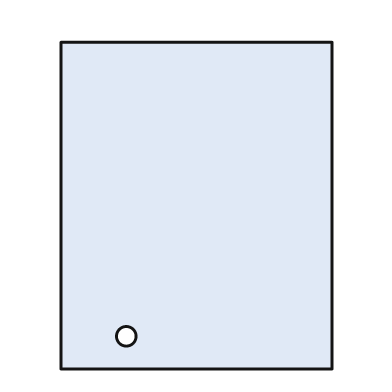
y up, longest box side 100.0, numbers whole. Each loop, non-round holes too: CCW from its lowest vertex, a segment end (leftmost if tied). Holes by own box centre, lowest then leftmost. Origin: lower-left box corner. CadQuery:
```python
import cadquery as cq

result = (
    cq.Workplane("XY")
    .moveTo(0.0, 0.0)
    .lineTo(83.0, 0.0)
    .lineTo(83.0, 100.0)
    .lineTo(0.0, 100.0)
    .close()
    .moveTo(20.0, 10.0)
    .circle(3.0)
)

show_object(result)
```